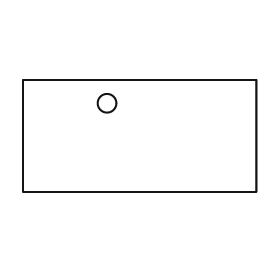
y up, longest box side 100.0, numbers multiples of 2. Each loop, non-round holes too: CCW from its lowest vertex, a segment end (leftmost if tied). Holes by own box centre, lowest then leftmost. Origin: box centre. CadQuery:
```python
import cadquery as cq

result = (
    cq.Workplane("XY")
    .moveTo(-50.0, -24.0)
    .lineTo(50.0, -24.0)
    .lineTo(50.0, 24.0)
    .lineTo(-50.0, 24.0)
    .close()
    .moveTo(-14.0, 14.0)
    .circle(4.0)
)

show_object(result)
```